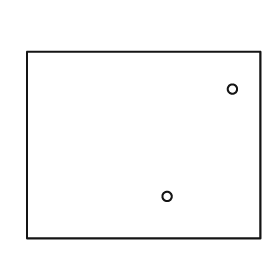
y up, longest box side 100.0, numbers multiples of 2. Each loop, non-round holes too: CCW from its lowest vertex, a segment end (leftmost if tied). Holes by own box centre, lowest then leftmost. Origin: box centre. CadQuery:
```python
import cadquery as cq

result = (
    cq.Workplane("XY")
    .moveTo(-50.0, -40.0)
    .lineTo(50.0, -40.0)
    .lineTo(50.0, 40.0)
    .lineTo(-50.0, 40.0)
    .close()
    .moveTo(10.0, -22.0)
    .circle(2.0)
    .moveTo(38.0, 24.0)
    .circle(2.0)
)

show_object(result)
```